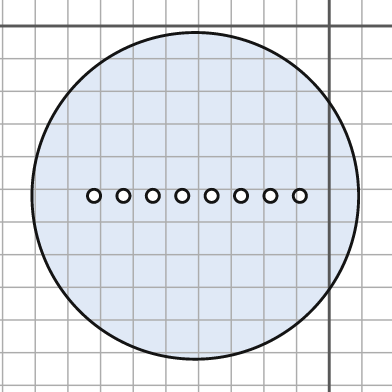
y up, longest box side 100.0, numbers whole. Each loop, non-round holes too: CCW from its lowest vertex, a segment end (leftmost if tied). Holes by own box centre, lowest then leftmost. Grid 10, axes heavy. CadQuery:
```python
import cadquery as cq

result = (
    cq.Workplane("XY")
    .moveTo(-41.0, -52.0)
    .circle(50.0)
    .moveTo(-72.0, -52.0)
    .circle(2.0)
    .moveTo(-63.0, -52.0)
    .circle(2.0)
    .moveTo(-54.0, -52.0)
    .circle(2.0)
    .moveTo(-45.0, -52.0)
    .circle(2.0)
    .moveTo(-36.0, -52.0)
    .circle(2.0)
    .moveTo(-27.0, -52.0)
    .circle(2.0)
    .moveTo(-18.0, -52.0)
    .circle(2.0)
    .moveTo(-9.0, -52.0)
    .circle(2.0)
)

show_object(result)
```